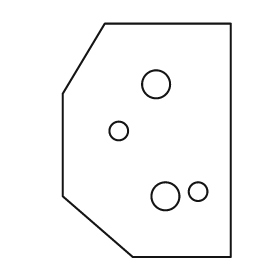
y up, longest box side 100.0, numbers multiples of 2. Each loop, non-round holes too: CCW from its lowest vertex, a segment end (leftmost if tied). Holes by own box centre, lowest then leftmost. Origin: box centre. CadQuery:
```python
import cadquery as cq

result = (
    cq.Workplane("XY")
    .moveTo(-6.0, -50.0)
    .lineTo(36.0, -50.0)
    .lineTo(36.0, 50.0)
    .lineTo(-18.0, 50.0)
    .lineTo(-36.0, 20.0)
    .lineTo(-36.0, -24.0)
    .close()
    .moveTo(8.0, -24.0)
    .circle(6.0)
    .moveTo(22.0, -22.0)
    .circle(4.0)
    .moveTo(-12.0, 4.0)
    .circle(4.0)
    .moveTo(4.0, 24.0)
    .circle(6.0)
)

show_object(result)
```